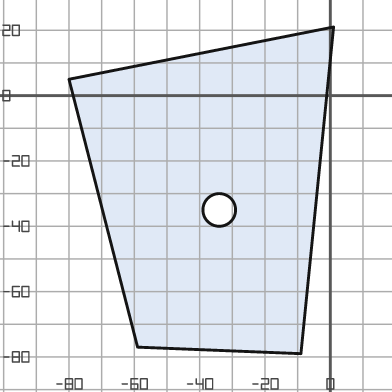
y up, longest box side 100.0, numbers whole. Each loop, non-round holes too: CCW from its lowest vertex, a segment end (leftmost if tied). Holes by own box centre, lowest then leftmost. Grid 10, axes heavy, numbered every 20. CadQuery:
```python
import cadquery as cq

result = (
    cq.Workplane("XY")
    .moveTo(-9.0, -79.0)
    .lineTo(1.0, 21.0)
    .lineTo(-80.0, 5.0)
    .lineTo(-59.0, -77.0)
    .close()
    .moveTo(-34.0, -35.0)
    .circle(5.0)
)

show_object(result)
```